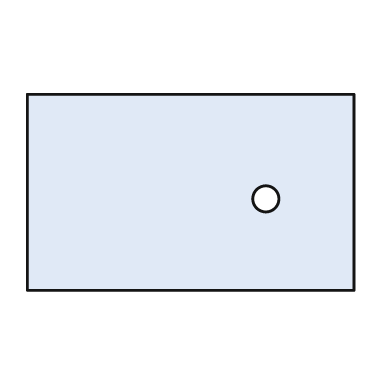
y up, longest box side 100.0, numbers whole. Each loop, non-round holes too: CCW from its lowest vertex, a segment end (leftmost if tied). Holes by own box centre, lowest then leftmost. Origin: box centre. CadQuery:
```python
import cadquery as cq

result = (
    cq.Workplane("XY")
    .moveTo(-50.0, -30.0)
    .lineTo(50.0, -30.0)
    .lineTo(50.0, 30.0)
    .lineTo(-50.0, 30.0)
    .close()
    .moveTo(23.0, -2.0)
    .circle(4.0)
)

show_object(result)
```